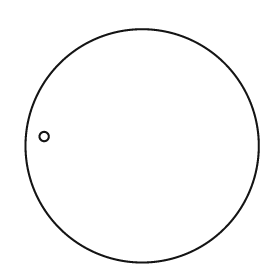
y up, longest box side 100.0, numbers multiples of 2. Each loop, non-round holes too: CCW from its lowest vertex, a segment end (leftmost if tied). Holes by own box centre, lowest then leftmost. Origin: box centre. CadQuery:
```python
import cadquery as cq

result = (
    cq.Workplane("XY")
    .moveTo(0.0, 0.0)
    .circle(50.0)
    .moveTo(-42.0, 4.0)
    .circle(2.0)
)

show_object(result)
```